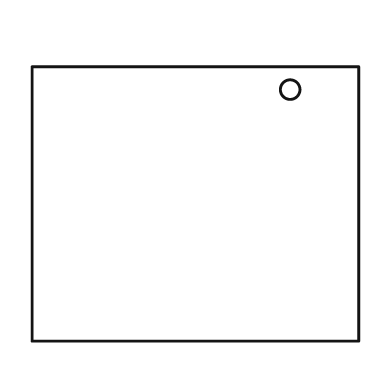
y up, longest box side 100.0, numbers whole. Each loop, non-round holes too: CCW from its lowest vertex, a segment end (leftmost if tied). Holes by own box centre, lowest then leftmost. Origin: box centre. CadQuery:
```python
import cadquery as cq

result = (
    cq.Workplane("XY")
    .moveTo(-50.0, -42.0)
    .lineTo(50.0, -42.0)
    .lineTo(50.0, 42.0)
    .lineTo(-50.0, 42.0)
    .close()
    .moveTo(29.0, 35.0)
    .circle(3.0)
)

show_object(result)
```